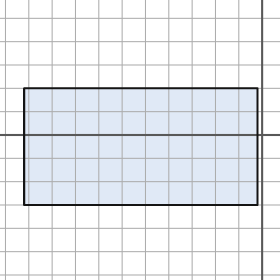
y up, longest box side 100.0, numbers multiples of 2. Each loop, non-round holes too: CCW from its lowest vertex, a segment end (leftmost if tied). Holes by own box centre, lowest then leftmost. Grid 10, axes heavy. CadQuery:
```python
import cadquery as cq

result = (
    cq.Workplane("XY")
    .moveTo(-102.0, -30.0)
    .lineTo(-2.0, -30.0)
    .lineTo(-2.0, 20.0)
    .lineTo(-102.0, 20.0)
    .close()
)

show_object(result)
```